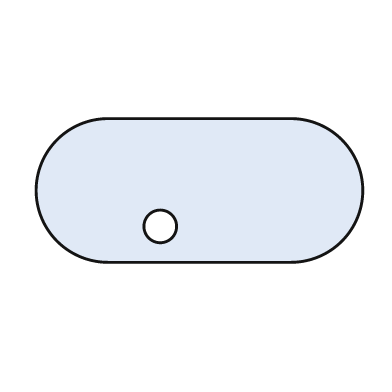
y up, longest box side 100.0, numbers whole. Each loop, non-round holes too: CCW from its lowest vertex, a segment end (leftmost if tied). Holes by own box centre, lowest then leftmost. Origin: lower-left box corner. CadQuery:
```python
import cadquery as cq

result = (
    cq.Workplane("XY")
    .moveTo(22.0, 0.0)
    .lineTo(78.0, 0.0)
    .threePointArc((100.0, 22.0), (78.0, 44.0))
    .lineTo(22.0, 44.0)
    .threePointArc((0.0, 22.0), (22.0, 0.0))
    .close()
    .moveTo(38.0, 11.0)
    .circle(5.0)
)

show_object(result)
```